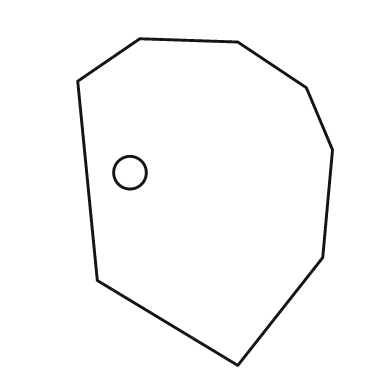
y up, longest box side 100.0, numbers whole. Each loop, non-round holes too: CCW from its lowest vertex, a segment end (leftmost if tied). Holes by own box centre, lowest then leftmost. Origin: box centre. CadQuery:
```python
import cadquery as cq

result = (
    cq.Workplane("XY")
    .moveTo(10.0, -50.0)
    .lineTo(36.0, -17.0)
    .lineTo(39.0, 16.0)
    .lineTo(31.0, 35.0)
    .lineTo(10.0, 49.0)
    .lineTo(-20.0, 50.0)
    .lineTo(-39.0, 37.0)
    .lineTo(-33.0, -24.0)
    .close()
    .moveTo(-23.0, 9.0)
    .circle(5.0)
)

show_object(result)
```